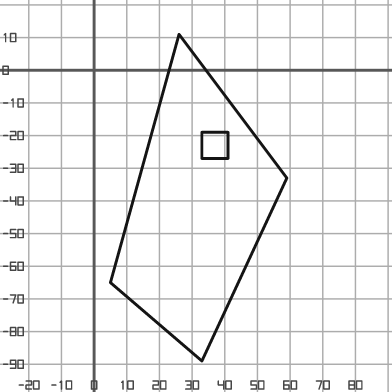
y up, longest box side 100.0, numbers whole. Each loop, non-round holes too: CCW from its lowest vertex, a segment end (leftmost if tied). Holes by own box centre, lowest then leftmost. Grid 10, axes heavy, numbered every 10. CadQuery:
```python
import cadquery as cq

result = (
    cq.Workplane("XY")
    .moveTo(33.0, -89.0)
    .lineTo(59.0, -33.0)
    .lineTo(26.0, 11.0)
    .lineTo(5.0, -65.0)
    .close()
    .moveTo(33.0, -27.0)
    .lineTo(41.0, -27.0)
    .lineTo(41.0, -19.0)
    .lineTo(33.0, -19.0)
    .close()
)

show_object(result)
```